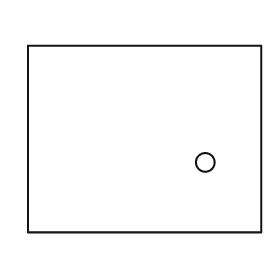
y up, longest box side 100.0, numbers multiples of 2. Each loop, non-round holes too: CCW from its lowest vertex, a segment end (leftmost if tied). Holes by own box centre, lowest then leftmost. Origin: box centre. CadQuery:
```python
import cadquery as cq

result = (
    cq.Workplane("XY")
    .moveTo(-50.0, -40.0)
    .lineTo(50.0, -40.0)
    .lineTo(50.0, 40.0)
    .lineTo(-50.0, 40.0)
    .close()
    .moveTo(26.0, -10.0)
    .circle(4.0)
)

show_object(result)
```